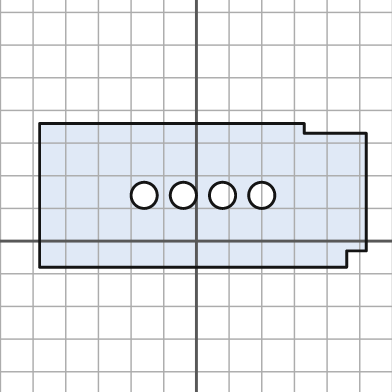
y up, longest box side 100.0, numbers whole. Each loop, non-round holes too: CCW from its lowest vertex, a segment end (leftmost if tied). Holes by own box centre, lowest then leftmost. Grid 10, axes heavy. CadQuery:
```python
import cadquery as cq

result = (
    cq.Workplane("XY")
    .moveTo(-48.0, -8.0)
    .lineTo(46.0, -8.0)
    .lineTo(46.0, -3.0)
    .lineTo(52.0, -3.0)
    .lineTo(52.0, 33.0)
    .lineTo(33.0, 33.0)
    .lineTo(33.0, 36.0)
    .lineTo(-48.0, 36.0)
    .close()
    .moveTo(-16.0, 14.0)
    .circle(4.0)
    .moveTo(-4.0, 14.0)
    .circle(4.0)
    .moveTo(8.0, 14.0)
    .circle(4.0)
    .moveTo(20.0, 14.0)
    .circle(4.0)
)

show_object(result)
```